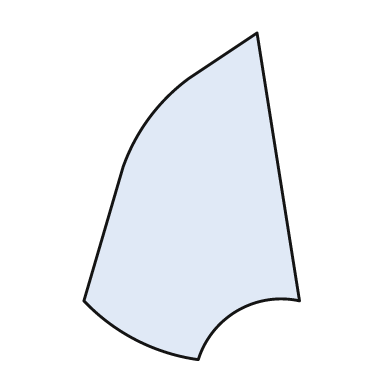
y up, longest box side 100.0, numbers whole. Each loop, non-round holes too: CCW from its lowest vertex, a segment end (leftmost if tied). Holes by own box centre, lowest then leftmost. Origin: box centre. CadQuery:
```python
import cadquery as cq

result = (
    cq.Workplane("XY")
    .moveTo(2.0, -50.0)
    .threePointArc((14.0, -35.0), (33.0, -32.0))
    .lineTo(20.0, 50.0)
    .lineTo(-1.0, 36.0)
    .threePointArc((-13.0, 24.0), (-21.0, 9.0))
    .lineTo(-33.0, -32.0)
    .threePointArc((-17.0, -44.0), (2.0, -50.0))
    .close()
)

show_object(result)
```